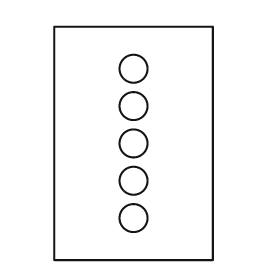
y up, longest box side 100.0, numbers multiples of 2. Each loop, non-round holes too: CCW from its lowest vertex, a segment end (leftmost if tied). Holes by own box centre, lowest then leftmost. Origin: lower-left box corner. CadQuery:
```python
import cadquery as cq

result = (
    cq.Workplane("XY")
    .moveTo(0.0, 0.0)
    .lineTo(68.0, 0.0)
    .lineTo(68.0, 100.0)
    .lineTo(0.0, 100.0)
    .close()
    .moveTo(34.0, 18.0)
    .circle(6.0)
    .moveTo(34.0, 34.0)
    .circle(6.0)
    .moveTo(34.0, 50.0)
    .circle(6.0)
    .moveTo(34.0, 66.0)
    .circle(6.0)
    .moveTo(34.0, 82.0)
    .circle(6.0)
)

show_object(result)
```